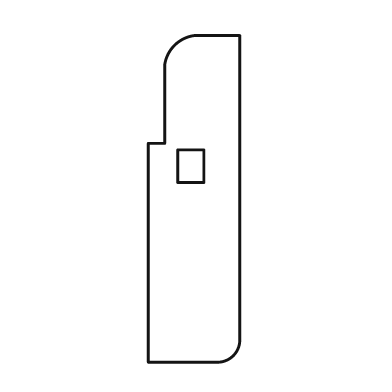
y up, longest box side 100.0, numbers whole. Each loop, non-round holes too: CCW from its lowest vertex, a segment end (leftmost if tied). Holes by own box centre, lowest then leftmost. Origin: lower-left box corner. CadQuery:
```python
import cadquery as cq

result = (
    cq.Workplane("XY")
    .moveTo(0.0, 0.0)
    .lineTo(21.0, 0.0)
    .threePointArc((26.0, 2.0), (28.0, 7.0))
    .lineTo(28.0, 100.0)
    .lineTo(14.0, 100.0)
    .threePointArc((8.0, 97.0), (5.0, 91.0))
    .lineTo(5.0, 67.0)
    .lineTo(0.0, 67.0)
    .close()
    .moveTo(9.0, 55.0)
    .lineTo(17.0, 55.0)
    .lineTo(17.0, 65.0)
    .lineTo(9.0, 65.0)
    .close()
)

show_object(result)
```